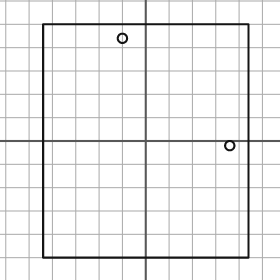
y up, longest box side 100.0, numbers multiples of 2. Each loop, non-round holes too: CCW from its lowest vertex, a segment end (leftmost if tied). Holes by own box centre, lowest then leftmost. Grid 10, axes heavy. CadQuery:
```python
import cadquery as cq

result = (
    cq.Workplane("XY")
    .moveTo(-44.0, -50.0)
    .lineTo(44.0, -50.0)
    .lineTo(44.0, 50.0)
    .lineTo(-44.0, 50.0)
    .close()
    .moveTo(36.0, -2.0)
    .circle(2.0)
    .moveTo(-10.0, 44.0)
    .circle(2.0)
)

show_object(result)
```